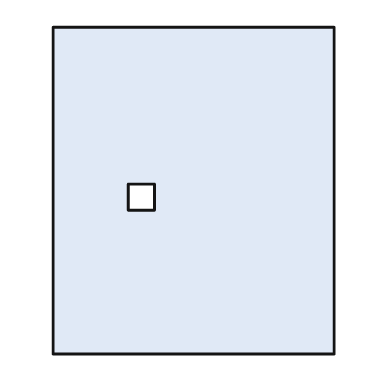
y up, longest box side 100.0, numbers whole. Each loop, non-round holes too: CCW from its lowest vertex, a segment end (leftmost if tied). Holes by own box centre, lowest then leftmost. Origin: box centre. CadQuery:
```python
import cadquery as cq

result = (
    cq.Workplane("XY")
    .moveTo(-43.0, -50.0)
    .lineTo(43.0, -50.0)
    .lineTo(43.0, 50.0)
    .lineTo(-43.0, 50.0)
    .close()
    .moveTo(-20.0, -6.0)
    .lineTo(-12.0, -6.0)
    .lineTo(-12.0, 2.0)
    .lineTo(-20.0, 2.0)
    .close()
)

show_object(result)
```